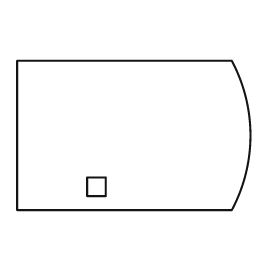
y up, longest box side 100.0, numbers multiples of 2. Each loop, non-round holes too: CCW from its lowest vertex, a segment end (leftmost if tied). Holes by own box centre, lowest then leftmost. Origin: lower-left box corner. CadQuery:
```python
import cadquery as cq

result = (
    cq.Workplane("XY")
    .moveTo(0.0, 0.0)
    .lineTo(92.0, 0.0)
    .threePointArc((100.0, 32.0), (92.0, 64.0))
    .lineTo(0.0, 64.0)
    .close()
    .moveTo(30.0, 6.0)
    .lineTo(38.0, 6.0)
    .lineTo(38.0, 14.0)
    .lineTo(30.0, 14.0)
    .close()
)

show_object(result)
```